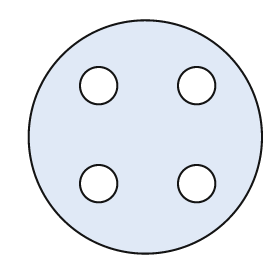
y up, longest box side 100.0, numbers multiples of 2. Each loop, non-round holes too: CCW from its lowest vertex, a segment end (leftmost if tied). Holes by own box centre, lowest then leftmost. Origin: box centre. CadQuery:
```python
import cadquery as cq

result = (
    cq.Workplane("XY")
    .moveTo(0.0, 0.0)
    .circle(50.0)
    .moveTo(-20.0, -20.0)
    .circle(8.0)
    .moveTo(22.0, -20.0)
    .circle(8.0)
    .moveTo(-20.0, 22.0)
    .circle(8.0)
    .moveTo(22.0, 22.0)
    .circle(8.0)
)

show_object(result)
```